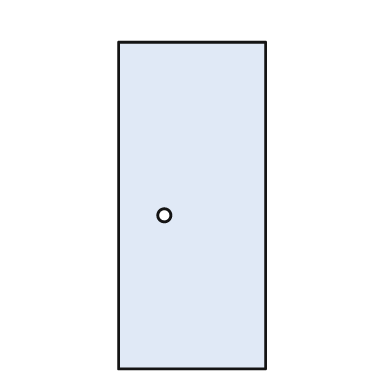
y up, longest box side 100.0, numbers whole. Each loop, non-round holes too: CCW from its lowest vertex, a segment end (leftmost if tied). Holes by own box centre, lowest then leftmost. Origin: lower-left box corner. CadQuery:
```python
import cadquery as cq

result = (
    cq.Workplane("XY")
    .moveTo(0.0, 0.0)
    .lineTo(45.0, 0.0)
    .lineTo(45.0, 100.0)
    .lineTo(0.0, 100.0)
    .close()
    .moveTo(14.0, 47.0)
    .circle(2.0)
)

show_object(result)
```